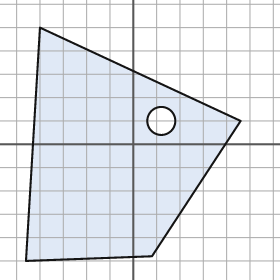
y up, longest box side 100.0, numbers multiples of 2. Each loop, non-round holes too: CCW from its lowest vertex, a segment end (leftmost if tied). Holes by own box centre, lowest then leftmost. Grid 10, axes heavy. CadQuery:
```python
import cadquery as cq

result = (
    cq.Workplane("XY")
    .moveTo(-46.0, -50.0)
    .lineTo(8.0, -48.0)
    .lineTo(46.0, 10.0)
    .lineTo(-40.0, 50.0)
    .close()
    .moveTo(12.0, 10.0)
    .circle(6.0)
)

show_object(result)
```